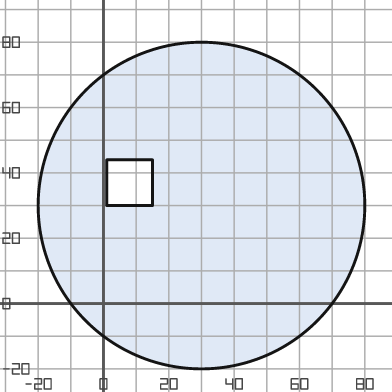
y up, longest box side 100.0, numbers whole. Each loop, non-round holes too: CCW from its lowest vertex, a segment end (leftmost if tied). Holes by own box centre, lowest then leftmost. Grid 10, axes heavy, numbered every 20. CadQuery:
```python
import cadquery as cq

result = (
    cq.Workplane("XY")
    .moveTo(30.0, 30.0)
    .circle(50.0)
    .moveTo(1.0, 30.0)
    .lineTo(15.0, 30.0)
    .lineTo(15.0, 44.0)
    .lineTo(1.0, 44.0)
    .close()
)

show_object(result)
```